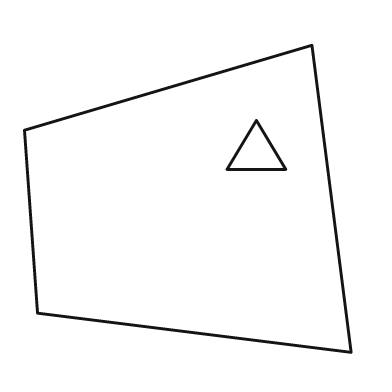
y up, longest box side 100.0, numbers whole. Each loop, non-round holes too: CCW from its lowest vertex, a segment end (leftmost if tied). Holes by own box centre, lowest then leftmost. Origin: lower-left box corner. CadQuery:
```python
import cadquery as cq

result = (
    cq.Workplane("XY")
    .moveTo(100.0, 0.0)
    .lineTo(88.0, 94.0)
    .lineTo(0.0, 68.0)
    .lineTo(4.0, 12.0)
    .close()
    .moveTo(62.0, 56.0)
    .lineTo(80.0, 56.0)
    .lineTo(71.0, 71.0)
    .close()
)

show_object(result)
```